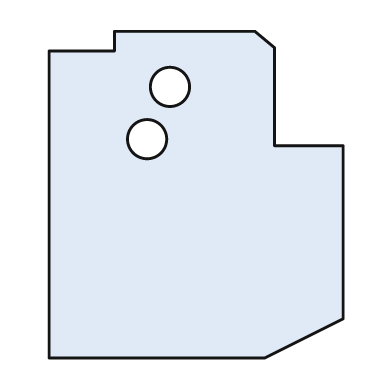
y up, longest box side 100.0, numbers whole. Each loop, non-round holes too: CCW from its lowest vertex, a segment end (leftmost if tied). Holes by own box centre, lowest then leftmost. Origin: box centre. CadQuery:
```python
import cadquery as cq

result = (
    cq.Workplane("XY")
    .moveTo(-45.0, -50.0)
    .lineTo(21.0, -50.0)
    .lineTo(45.0, -38.0)
    .lineTo(45.0, 15.0)
    .lineTo(24.0, 15.0)
    .lineTo(24.0, 45.0)
    .lineTo(18.0, 50.0)
    .lineTo(-25.0, 50.0)
    .lineTo(-25.0, 44.0)
    .lineTo(-45.0, 44.0)
    .close()
    .moveTo(-15.0, 17.0)
    .circle(6.0)
    .moveTo(-8.0, 33.0)
    .circle(6.0)
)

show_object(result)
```